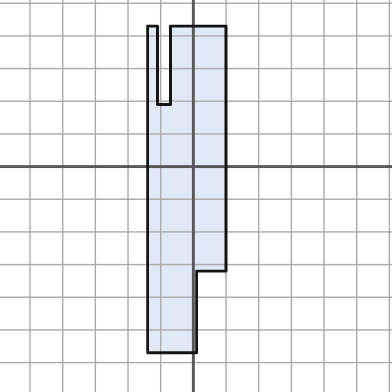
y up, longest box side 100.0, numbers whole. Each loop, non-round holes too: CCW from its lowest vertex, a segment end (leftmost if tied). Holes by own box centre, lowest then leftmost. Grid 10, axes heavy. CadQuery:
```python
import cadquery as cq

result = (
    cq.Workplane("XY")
    .moveTo(-14.0, -57.0)
    .lineTo(1.0, -57.0)
    .lineTo(1.0, -32.0)
    .lineTo(10.0, -32.0)
    .lineTo(10.0, 43.0)
    .lineTo(-7.0, 43.0)
    .lineTo(-7.0, 19.0)
    .lineTo(-11.0, 19.0)
    .lineTo(-11.0, 43.0)
    .lineTo(-14.0, 43.0)
    .close()
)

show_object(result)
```